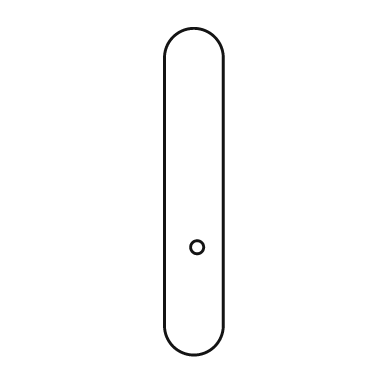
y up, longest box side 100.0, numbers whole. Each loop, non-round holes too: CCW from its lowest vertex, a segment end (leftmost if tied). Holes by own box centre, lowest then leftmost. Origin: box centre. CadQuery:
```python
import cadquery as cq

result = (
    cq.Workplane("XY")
    .moveTo(-9.0, -41.0)
    .threePointArc((0.0, -50.0), (9.0, -41.0))
    .lineTo(9.0, 41.0)
    .threePointArc((0.0, 50.0), (-9.0, 41.0))
    .close()
    .moveTo(1.0, -17.0)
    .circle(2.0)
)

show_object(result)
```